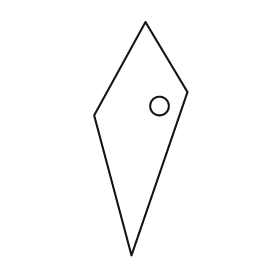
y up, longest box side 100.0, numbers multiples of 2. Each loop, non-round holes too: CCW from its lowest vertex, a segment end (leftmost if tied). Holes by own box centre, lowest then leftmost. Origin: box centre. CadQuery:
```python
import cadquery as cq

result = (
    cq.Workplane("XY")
    .moveTo(-4.0, -50.0)
    .lineTo(20.0, 20.0)
    .lineTo(2.0, 50.0)
    .lineTo(-20.0, 10.0)
    .close()
    .moveTo(8.0, 14.0)
    .circle(4.0)
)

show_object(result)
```